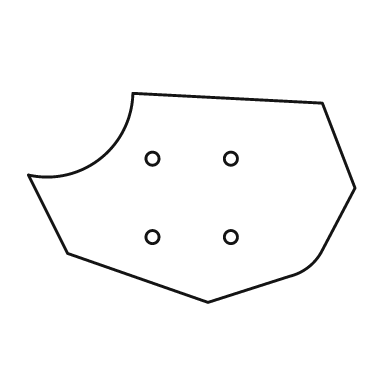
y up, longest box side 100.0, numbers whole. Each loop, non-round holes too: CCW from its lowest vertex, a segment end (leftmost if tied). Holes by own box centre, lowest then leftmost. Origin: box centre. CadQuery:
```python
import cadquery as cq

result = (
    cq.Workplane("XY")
    .moveTo(5.0, -32.0)
    .lineTo(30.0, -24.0)
    .threePointArc((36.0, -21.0), (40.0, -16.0))
    .lineTo(50.0, 3.0)
    .lineTo(40.0, 29.0)
    .lineTo(-18.0, 32.0)
    .threePointArc((-28.0, 12.0), (-50.0, 7.0))
    .lineTo(-38.0, -17.0)
    .close()
    .moveTo(-12.0, -12.0)
    .circle(2.0)
    .moveTo(12.0, -12.0)
    .circle(2.0)
    .moveTo(-12.0, 12.0)
    .circle(2.0)
    .moveTo(12.0, 12.0)
    .circle(2.0)
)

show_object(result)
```